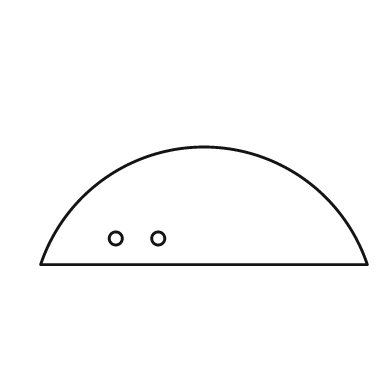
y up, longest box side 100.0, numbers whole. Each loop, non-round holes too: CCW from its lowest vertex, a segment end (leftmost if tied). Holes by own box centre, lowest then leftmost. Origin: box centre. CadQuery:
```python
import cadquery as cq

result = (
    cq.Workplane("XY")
    .moveTo(-50.0, -18.0)
    .lineTo(50.0, -18.0)
    .threePointArc((0.0, 18.0), (-50.0, -18.0))
    .close()
    .moveTo(-27.0, -10.0)
    .circle(2.0)
    .moveTo(-14.0, -10.0)
    .circle(2.0)
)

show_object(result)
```